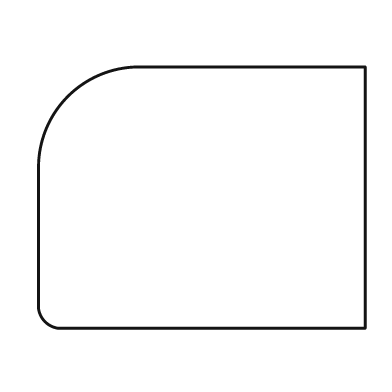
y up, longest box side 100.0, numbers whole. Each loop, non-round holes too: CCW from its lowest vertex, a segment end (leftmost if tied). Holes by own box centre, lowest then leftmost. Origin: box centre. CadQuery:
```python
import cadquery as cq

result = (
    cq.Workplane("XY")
    .moveTo(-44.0, -40.0)
    .lineTo(50.0, -40.0)
    .lineTo(50.0, 40.0)
    .lineTo(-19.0, 40.0)
    .threePointArc((-41.0, 31.0), (-50.0, 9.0))
    .lineTo(-50.0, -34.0)
    .threePointArc((-48.0, -38.0), (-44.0, -40.0))
    .close()
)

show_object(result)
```